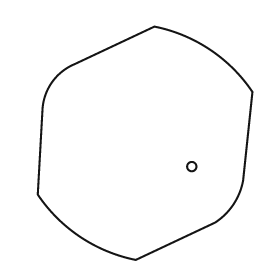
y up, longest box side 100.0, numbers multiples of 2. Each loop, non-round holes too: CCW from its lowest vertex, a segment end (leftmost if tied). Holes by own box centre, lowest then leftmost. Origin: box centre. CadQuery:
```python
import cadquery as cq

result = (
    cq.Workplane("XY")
    .moveTo(-4.0, -50.0)
    .lineTo(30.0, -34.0)
    .threePointArc((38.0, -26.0), (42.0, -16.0))
    .lineTo(46.0, 22.0)
    .threePointArc((28.0, 40.0), (4.0, 50.0))
    .lineTo(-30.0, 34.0)
    .threePointArc((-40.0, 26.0), (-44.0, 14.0))
    .lineTo(-46.0, -22.0)
    .threePointArc((-28.0, -40.0), (-4.0, -50.0))
    .close()
    .moveTo(20.0, -10.0)
    .circle(2.0)
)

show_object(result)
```